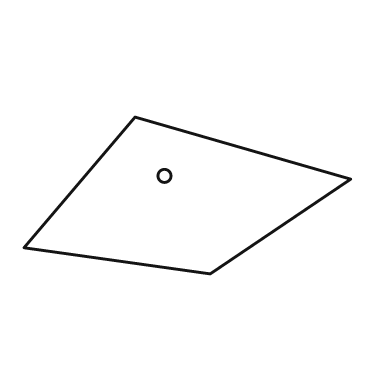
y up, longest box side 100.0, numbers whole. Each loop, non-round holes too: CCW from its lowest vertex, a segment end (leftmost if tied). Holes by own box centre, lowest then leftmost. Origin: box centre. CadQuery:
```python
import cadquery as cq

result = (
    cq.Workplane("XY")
    .moveTo(7.0, -24.0)
    .lineTo(50.0, 5.0)
    .lineTo(-16.0, 24.0)
    .lineTo(-50.0, -16.0)
    .close()
    .moveTo(-7.0, 6.0)
    .circle(2.0)
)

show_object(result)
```